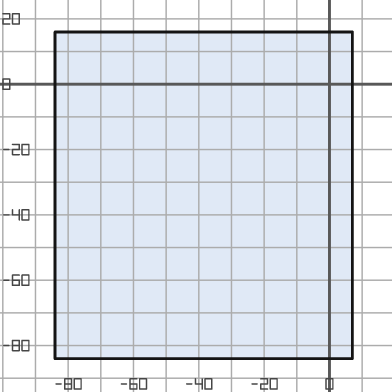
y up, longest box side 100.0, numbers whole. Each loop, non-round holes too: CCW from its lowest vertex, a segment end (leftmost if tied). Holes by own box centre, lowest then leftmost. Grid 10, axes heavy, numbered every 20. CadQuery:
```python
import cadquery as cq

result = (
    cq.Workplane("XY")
    .moveTo(-84.0, -84.0)
    .lineTo(7.0, -84.0)
    .lineTo(7.0, 16.0)
    .lineTo(-84.0, 16.0)
    .close()
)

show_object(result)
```